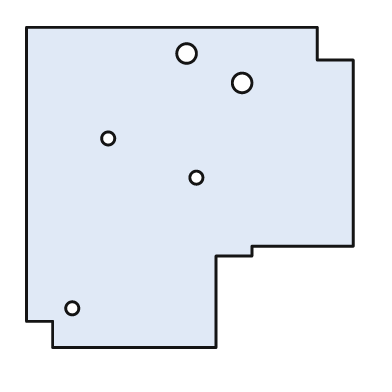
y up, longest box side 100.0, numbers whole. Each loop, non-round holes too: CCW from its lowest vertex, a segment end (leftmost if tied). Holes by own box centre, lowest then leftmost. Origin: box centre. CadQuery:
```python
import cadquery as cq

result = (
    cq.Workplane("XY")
    .moveTo(-42.0, -49.0)
    .lineTo(8.0, -49.0)
    .lineTo(8.0, -21.0)
    .lineTo(19.0, -21.0)
    .lineTo(19.0, -18.0)
    .lineTo(50.0, -18.0)
    .lineTo(50.0, 39.0)
    .lineTo(39.0, 39.0)
    .lineTo(39.0, 49.0)
    .lineTo(-50.0, 49.0)
    .lineTo(-50.0, -41.0)
    .lineTo(-42.0, -41.0)
    .close()
    .moveTo(-36.0, -37.0)
    .circle(2.0)
    .moveTo(2.0, 3.0)
    .circle(2.0)
    .moveTo(-25.0, 15.0)
    .circle(2.0)
    .moveTo(16.0, 32.0)
    .circle(3.0)
    .moveTo(-1.0, 41.0)
    .circle(3.0)
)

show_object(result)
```